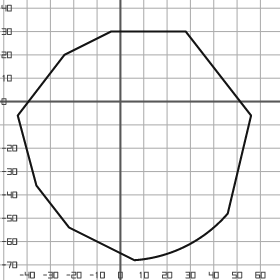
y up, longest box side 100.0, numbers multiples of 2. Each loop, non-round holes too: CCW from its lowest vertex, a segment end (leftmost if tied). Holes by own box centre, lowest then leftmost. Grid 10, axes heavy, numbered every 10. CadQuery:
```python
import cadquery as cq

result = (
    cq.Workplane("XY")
    .moveTo(6.0, -68.0)
    .threePointArc((28.0, -62.0), (46.0, -48.0))
    .lineTo(56.0, -6.0)
    .lineTo(28.0, 30.0)
    .lineTo(-4.0, 30.0)
    .lineTo(-24.0, 20.0)
    .lineTo(-44.0, -6.0)
    .lineTo(-36.0, -36.0)
    .lineTo(-22.0, -54.0)
    .close()
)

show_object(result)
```